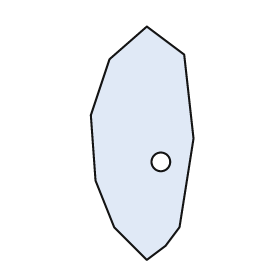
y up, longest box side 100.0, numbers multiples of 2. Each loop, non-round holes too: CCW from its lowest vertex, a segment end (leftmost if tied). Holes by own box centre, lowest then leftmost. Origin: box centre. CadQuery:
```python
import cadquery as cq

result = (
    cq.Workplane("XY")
    .moveTo(2.0, -50.0)
    .lineTo(10.0, -44.0)
    .lineTo(16.0, -36.0)
    .lineTo(22.0, 2.0)
    .lineTo(18.0, 38.0)
    .lineTo(2.0, 50.0)
    .lineTo(-14.0, 36.0)
    .lineTo(-22.0, 12.0)
    .lineTo(-20.0, -16.0)
    .lineTo(-12.0, -36.0)
    .close()
    .moveTo(8.0, -8.0)
    .circle(4.0)
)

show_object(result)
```